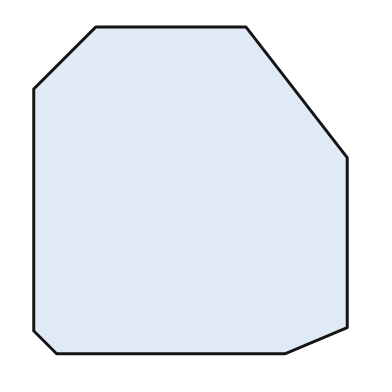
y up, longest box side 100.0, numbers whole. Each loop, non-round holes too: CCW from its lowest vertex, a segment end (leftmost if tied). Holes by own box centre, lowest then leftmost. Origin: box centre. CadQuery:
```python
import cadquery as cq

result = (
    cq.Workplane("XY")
    .moveTo(-41.0, -50.0)
    .lineTo(29.0, -50.0)
    .lineTo(48.0, -42.0)
    .lineTo(48.0, 10.0)
    .lineTo(17.0, 50.0)
    .lineTo(-29.0, 50.0)
    .lineTo(-48.0, 31.0)
    .lineTo(-48.0, -43.0)
    .close()
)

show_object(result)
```